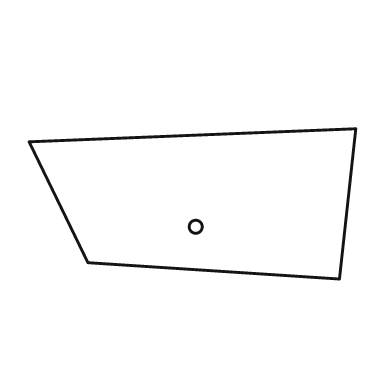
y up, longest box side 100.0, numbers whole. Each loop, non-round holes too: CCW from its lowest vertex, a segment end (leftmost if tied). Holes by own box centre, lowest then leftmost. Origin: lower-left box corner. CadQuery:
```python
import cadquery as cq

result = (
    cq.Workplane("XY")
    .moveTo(95.0, 0.0)
    .lineTo(100.0, 46.0)
    .lineTo(0.0, 42.0)
    .lineTo(18.0, 5.0)
    .close()
    .moveTo(51.0, 16.0)
    .circle(2.0)
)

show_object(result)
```